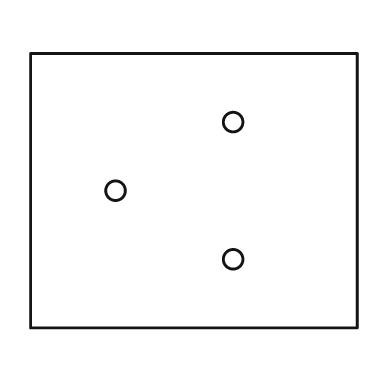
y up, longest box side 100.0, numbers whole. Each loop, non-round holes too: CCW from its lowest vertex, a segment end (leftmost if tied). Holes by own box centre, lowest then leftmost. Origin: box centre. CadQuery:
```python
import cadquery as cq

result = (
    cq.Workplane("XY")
    .moveTo(-50.0, -42.0)
    .lineTo(50.0, -42.0)
    .lineTo(50.0, 42.0)
    .lineTo(-50.0, 42.0)
    .close()
    .moveTo(12.0, -21.0)
    .circle(3.0)
    .moveTo(-24.0, 0.0)
    .circle(3.0)
    .moveTo(12.0, 21.0)
    .circle(3.0)
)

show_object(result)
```